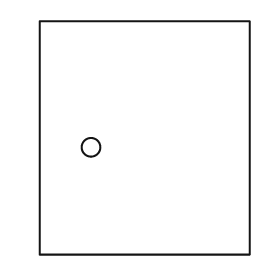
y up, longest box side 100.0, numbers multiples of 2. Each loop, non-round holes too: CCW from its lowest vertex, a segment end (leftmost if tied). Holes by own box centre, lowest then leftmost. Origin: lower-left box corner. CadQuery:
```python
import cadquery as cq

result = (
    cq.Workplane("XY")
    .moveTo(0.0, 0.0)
    .lineTo(90.0, 0.0)
    .lineTo(90.0, 100.0)
    .lineTo(0.0, 100.0)
    .close()
    .moveTo(22.0, 46.0)
    .circle(4.0)
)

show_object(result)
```